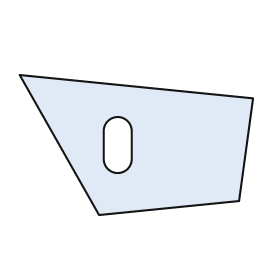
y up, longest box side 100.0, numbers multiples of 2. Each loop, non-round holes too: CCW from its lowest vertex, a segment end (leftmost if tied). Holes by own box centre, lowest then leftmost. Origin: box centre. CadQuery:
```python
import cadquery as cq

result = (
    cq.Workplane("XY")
    .moveTo(-16.0, -30.0)
    .lineTo(44.0, -24.0)
    .lineTo(50.0, 20.0)
    .lineTo(-50.0, 30.0)
    .close()
    .moveTo(-14.0, -6.0)
    .threePointArc((-8.0, -12.0), (-2.0, -6.0))
    .lineTo(-2.0, 6.0)
    .threePointArc((-8.0, 12.0), (-14.0, 6.0))
    .close()
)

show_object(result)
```